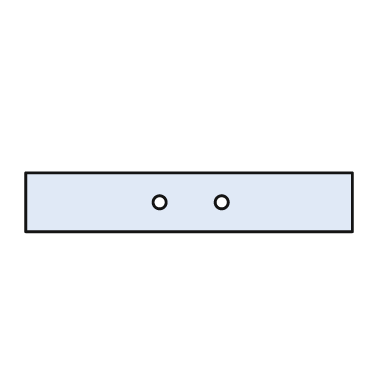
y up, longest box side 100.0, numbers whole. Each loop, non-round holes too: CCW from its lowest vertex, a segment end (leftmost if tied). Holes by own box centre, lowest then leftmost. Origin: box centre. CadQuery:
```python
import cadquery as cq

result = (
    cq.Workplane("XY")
    .moveTo(-50.0, -9.0)
    .lineTo(50.0, -9.0)
    .lineTo(50.0, 9.0)
    .lineTo(-50.0, 9.0)
    .close()
    .moveTo(-9.0, 0.0)
    .circle(2.0)
    .moveTo(10.0, 0.0)
    .circle(2.0)
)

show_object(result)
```